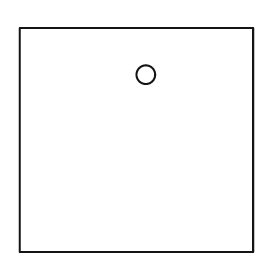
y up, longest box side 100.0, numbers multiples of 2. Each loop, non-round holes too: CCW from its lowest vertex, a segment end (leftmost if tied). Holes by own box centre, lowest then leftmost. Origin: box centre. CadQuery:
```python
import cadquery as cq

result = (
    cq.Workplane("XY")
    .moveTo(-50.0, -48.0)
    .lineTo(50.0, -48.0)
    .lineTo(50.0, 48.0)
    .lineTo(-50.0, 48.0)
    .close()
    .moveTo(4.0, 28.0)
    .circle(4.0)
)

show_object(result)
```